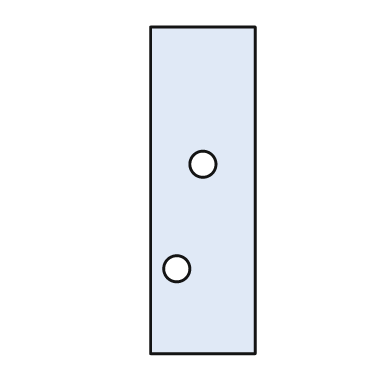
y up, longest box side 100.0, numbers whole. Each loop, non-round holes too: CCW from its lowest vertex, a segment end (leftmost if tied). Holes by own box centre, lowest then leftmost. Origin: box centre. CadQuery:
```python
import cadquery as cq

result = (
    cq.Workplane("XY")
    .moveTo(-16.0, -50.0)
    .lineTo(16.0, -50.0)
    .lineTo(16.0, 50.0)
    .lineTo(-16.0, 50.0)
    .close()
    .moveTo(-8.0, -24.0)
    .circle(4.0)
    .moveTo(0.0, 8.0)
    .circle(4.0)
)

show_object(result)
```